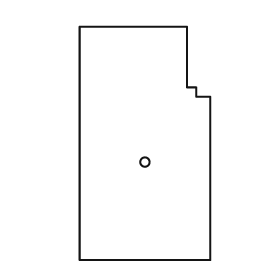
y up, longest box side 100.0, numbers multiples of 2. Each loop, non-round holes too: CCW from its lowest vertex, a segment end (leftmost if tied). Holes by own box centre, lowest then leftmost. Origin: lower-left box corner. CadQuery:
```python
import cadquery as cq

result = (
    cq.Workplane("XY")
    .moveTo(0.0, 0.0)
    .lineTo(56.0, 0.0)
    .lineTo(56.0, 70.0)
    .lineTo(50.0, 70.0)
    .lineTo(50.0, 74.0)
    .lineTo(46.0, 74.0)
    .lineTo(46.0, 100.0)
    .lineTo(0.0, 100.0)
    .close()
    .moveTo(28.0, 42.0)
    .circle(2.0)
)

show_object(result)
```